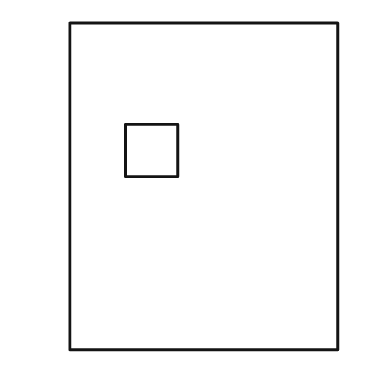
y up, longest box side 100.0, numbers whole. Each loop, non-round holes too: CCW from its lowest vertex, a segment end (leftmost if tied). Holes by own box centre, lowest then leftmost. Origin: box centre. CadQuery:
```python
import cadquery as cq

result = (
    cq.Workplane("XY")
    .moveTo(-41.0, -50.0)
    .lineTo(41.0, -50.0)
    .lineTo(41.0, 50.0)
    .lineTo(-41.0, 50.0)
    .close()
    .moveTo(-24.0, 3.0)
    .lineTo(-8.0, 3.0)
    .lineTo(-8.0, 19.0)
    .lineTo(-24.0, 19.0)
    .close()
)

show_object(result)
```